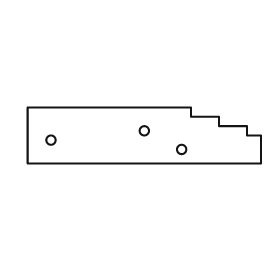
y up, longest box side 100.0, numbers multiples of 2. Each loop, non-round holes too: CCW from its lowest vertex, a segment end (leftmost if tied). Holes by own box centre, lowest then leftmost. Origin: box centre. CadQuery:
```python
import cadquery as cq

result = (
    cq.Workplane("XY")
    .moveTo(-50.0, -12.0)
    .lineTo(50.0, -12.0)
    .lineTo(50.0, 0.0)
    .lineTo(44.0, 0.0)
    .lineTo(44.0, 4.0)
    .lineTo(32.0, 4.0)
    .lineTo(32.0, 8.0)
    .lineTo(20.0, 8.0)
    .lineTo(20.0, 12.0)
    .lineTo(-50.0, 12.0)
    .close()
    .moveTo(16.0, -6.0)
    .circle(2.0)
    .moveTo(-40.0, -2.0)
    .circle(2.0)
    .moveTo(0.0, 2.0)
    .circle(2.0)
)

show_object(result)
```